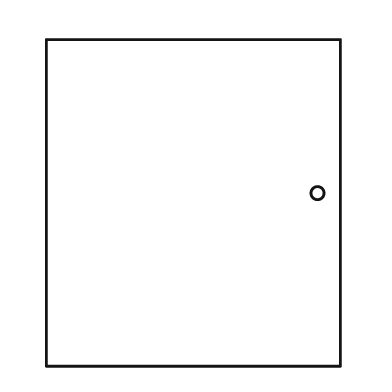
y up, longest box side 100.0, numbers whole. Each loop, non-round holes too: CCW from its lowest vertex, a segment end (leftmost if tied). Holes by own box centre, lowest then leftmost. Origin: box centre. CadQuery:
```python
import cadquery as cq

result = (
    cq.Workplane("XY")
    .moveTo(-45.0, -50.0)
    .lineTo(45.0, -50.0)
    .lineTo(45.0, 50.0)
    .lineTo(-45.0, 50.0)
    .close()
    .moveTo(38.0, 3.0)
    .circle(2.0)
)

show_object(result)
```